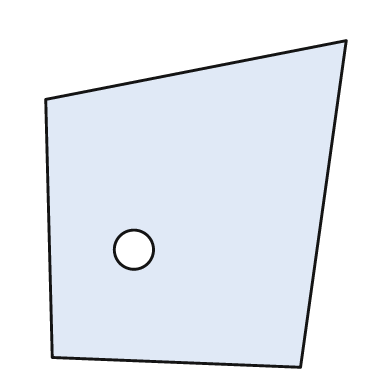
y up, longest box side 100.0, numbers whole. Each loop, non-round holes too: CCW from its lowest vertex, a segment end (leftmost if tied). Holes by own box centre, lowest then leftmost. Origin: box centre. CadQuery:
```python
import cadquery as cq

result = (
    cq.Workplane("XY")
    .moveTo(32.0, -50.0)
    .lineTo(46.0, 50.0)
    .lineTo(-46.0, 32.0)
    .lineTo(-44.0, -47.0)
    .close()
    .moveTo(-19.0, -14.0)
    .circle(6.0)
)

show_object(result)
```